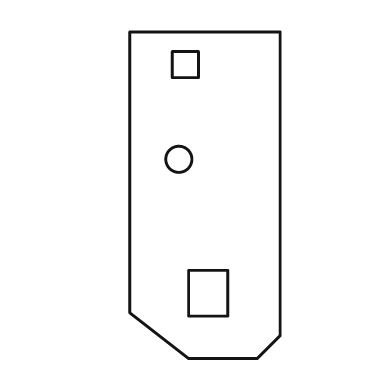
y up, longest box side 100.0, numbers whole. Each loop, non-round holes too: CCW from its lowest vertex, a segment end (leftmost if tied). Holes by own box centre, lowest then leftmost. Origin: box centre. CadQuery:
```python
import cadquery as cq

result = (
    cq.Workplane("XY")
    .moveTo(-5.0, -50.0)
    .lineTo(16.0, -50.0)
    .lineTo(23.0, -43.0)
    .lineTo(23.0, 50.0)
    .lineTo(-23.0, 50.0)
    .lineTo(-23.0, -36.0)
    .close()
    .moveTo(-5.0, -37.0)
    .lineTo(7.0, -37.0)
    .lineTo(7.0, -23.0)
    .lineTo(-5.0, -23.0)
    .close()
    .moveTo(-8.0, 11.0)
    .circle(4.0)
    .moveTo(-10.0, 36.0)
    .lineTo(-2.0, 36.0)
    .lineTo(-2.0, 44.0)
    .lineTo(-10.0, 44.0)
    .close()
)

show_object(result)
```